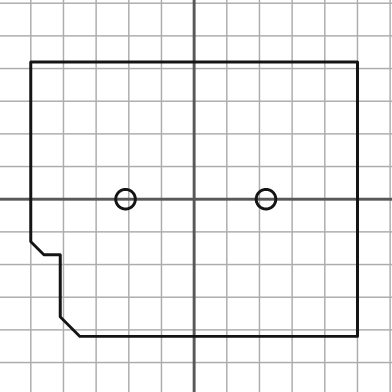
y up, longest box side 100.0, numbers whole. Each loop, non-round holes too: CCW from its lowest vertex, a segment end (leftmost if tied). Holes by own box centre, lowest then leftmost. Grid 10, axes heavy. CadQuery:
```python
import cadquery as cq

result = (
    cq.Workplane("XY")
    .moveTo(-35.0, -42.0)
    .lineTo(50.0, -42.0)
    .lineTo(50.0, 42.0)
    .lineTo(-50.0, 42.0)
    .lineTo(-50.0, -13.0)
    .lineTo(-46.0, -17.0)
    .lineTo(-41.0, -17.0)
    .lineTo(-41.0, -36.0)
    .close()
    .moveTo(-21.0, 0.0)
    .circle(3.0)
    .moveTo(22.0, 0.0)
    .circle(3.0)
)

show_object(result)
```